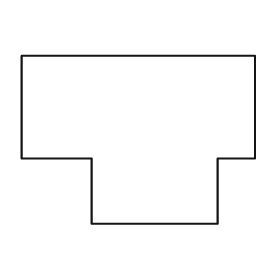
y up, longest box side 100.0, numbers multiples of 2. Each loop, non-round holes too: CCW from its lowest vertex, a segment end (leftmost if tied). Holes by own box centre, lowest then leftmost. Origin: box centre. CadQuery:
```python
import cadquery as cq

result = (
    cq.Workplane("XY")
    .moveTo(-20.0, -36.0)
    .lineTo(34.0, -36.0)
    .lineTo(34.0, -8.0)
    .lineTo(50.0, -8.0)
    .lineTo(50.0, 36.0)
    .lineTo(-50.0, 36.0)
    .lineTo(-50.0, -8.0)
    .lineTo(-20.0, -8.0)
    .close()
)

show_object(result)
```